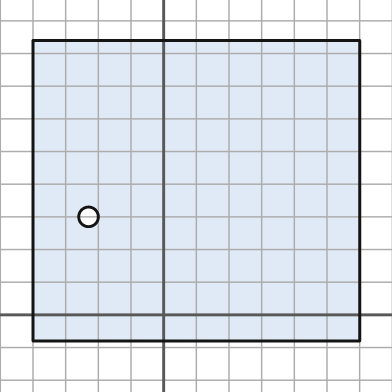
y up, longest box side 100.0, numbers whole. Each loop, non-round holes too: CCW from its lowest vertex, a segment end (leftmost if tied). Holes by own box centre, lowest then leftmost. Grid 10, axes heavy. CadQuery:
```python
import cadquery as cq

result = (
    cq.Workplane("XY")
    .moveTo(-40.0, -8.0)
    .lineTo(60.0, -8.0)
    .lineTo(60.0, 84.0)
    .lineTo(-40.0, 84.0)
    .close()
    .moveTo(-23.0, 30.0)
    .circle(3.0)
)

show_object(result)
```